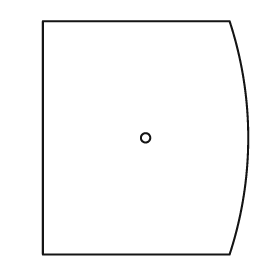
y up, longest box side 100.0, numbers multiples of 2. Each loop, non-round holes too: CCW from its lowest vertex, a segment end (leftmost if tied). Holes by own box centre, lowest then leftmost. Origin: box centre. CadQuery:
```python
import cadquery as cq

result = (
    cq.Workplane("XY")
    .moveTo(-44.0, -50.0)
    .lineTo(36.0, -50.0)
    .threePointArc((44.0, 0.0), (36.0, 50.0))
    .lineTo(-44.0, 50.0)
    .close()
    .moveTo(0.0, 0.0)
    .circle(2.0)
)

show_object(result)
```